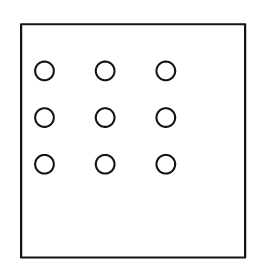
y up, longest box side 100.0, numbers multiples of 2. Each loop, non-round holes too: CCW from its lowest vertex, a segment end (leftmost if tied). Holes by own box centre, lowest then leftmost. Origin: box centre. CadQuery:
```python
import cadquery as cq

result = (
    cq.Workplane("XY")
    .moveTo(-48.0, -50.0)
    .lineTo(48.0, -50.0)
    .lineTo(48.0, 50.0)
    .lineTo(-48.0, 50.0)
    .close()
    .moveTo(-38.0, -10.0)
    .circle(4.0)
    .moveTo(-12.0, -10.0)
    .circle(4.0)
    .moveTo(14.0, -10.0)
    .circle(4.0)
    .moveTo(-38.0, 10.0)
    .circle(4.0)
    .moveTo(-12.0, 10.0)
    .circle(4.0)
    .moveTo(14.0, 10.0)
    .circle(4.0)
    .moveTo(-38.0, 30.0)
    .circle(4.0)
    .moveTo(-12.0, 30.0)
    .circle(4.0)
    .moveTo(14.0, 30.0)
    .circle(4.0)
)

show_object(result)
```